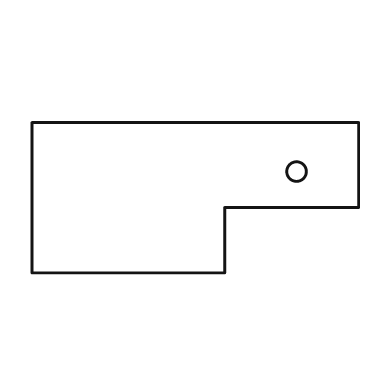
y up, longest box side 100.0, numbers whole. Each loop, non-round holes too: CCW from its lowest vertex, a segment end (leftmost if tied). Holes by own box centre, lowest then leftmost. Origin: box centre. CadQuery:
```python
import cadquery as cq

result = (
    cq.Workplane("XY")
    .moveTo(-50.0, -23.0)
    .lineTo(9.0, -23.0)
    .lineTo(9.0, -3.0)
    .lineTo(50.0, -3.0)
    .lineTo(50.0, 23.0)
    .lineTo(-50.0, 23.0)
    .close()
    .moveTo(31.0, 8.0)
    .circle(3.0)
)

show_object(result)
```